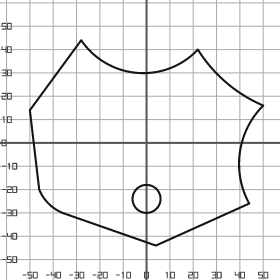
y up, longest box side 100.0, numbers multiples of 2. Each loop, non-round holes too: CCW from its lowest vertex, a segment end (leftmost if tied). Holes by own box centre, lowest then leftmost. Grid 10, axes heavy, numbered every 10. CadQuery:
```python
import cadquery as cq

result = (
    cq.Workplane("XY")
    .moveTo(4.0, -44.0)
    .lineTo(44.0, -26.0)
    .threePointArc((40.0, -4.0), (50.0, 16.0))
    .threePointArc((34.0, 26.0), (22.0, 40.0))
    .threePointArc((-4.0, 30.0), (-28.0, 44.0))
    .lineTo(-50.0, 14.0)
    .lineTo(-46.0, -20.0)
    .threePointArc((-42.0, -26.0), (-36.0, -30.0))
    .close()
    .moveTo(0.0, -24.0)
    .circle(6.0)
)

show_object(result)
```